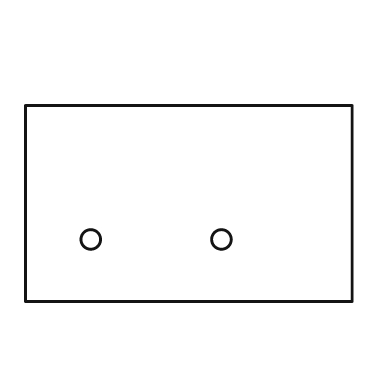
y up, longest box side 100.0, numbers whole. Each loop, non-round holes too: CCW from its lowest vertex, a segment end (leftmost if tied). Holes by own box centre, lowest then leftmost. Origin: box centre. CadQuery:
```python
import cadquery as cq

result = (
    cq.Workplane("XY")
    .moveTo(-50.0, -30.0)
    .lineTo(50.0, -30.0)
    .lineTo(50.0, 30.0)
    .lineTo(-50.0, 30.0)
    .close()
    .moveTo(-30.0, -11.0)
    .circle(3.0)
    .moveTo(10.0, -11.0)
    .circle(3.0)
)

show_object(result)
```